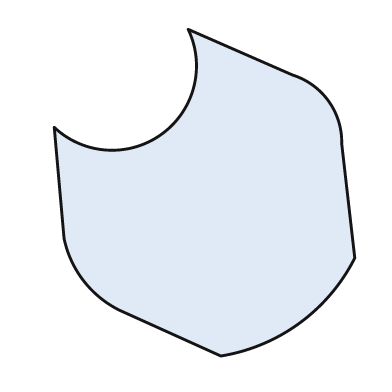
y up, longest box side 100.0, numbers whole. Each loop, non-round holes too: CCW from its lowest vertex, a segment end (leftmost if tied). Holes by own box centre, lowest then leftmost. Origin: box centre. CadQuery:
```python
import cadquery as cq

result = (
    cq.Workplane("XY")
    .moveTo(5.0, -50.0)
    .threePointArc((29.0, -40.0), (46.0, -20.0))
    .lineTo(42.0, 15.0)
    .threePointArc((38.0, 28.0), (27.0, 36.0))
    .lineTo(-5.0, 50.0)
    .threePointArc((-13.0, 18.0), (-46.0, 20.0))
    .lineTo(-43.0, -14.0)
    .threePointArc((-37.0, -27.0), (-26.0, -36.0))
    .close()
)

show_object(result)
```